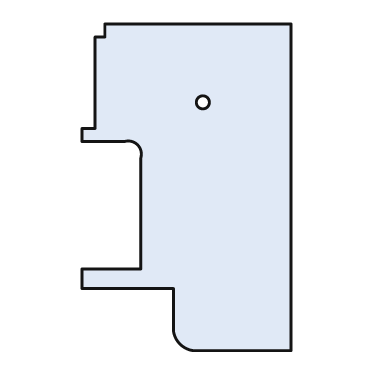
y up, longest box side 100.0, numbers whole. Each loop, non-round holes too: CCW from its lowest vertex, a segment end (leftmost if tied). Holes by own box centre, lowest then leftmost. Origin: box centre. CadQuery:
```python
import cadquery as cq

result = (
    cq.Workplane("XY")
    .moveTo(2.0, -50.0)
    .lineTo(32.0, -50.0)
    .lineTo(32.0, 50.0)
    .lineTo(-25.0, 50.0)
    .lineTo(-25.0, 46.0)
    .lineTo(-28.0, 46.0)
    .lineTo(-28.0, 18.0)
    .lineTo(-32.0, 18.0)
    .lineTo(-32.0, 14.0)
    .lineTo(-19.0, 14.0)
    .threePointArc((-15.0, 13.0), (-14.0, 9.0))
    .lineTo(-14.0, -25.0)
    .lineTo(-32.0, -25.0)
    .lineTo(-32.0, -31.0)
    .lineTo(-4.0, -31.0)
    .lineTo(-4.0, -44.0)
    .threePointArc((-2.0, -48.0), (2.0, -50.0))
    .close()
    .moveTo(5.0, 26.0)
    .circle(2.0)
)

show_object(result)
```